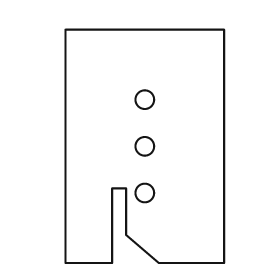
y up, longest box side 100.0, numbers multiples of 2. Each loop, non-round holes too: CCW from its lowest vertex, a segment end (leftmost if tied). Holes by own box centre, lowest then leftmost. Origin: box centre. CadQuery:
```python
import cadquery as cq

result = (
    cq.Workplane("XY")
    .moveTo(-34.0, -50.0)
    .lineTo(-14.0, -50.0)
    .lineTo(-14.0, -18.0)
    .lineTo(-8.0, -18.0)
    .lineTo(-8.0, -38.0)
    .lineTo(6.0, -50.0)
    .lineTo(34.0, -50.0)
    .lineTo(34.0, 50.0)
    .lineTo(-34.0, 50.0)
    .close()
    .moveTo(0.0, -20.0)
    .circle(4.0)
    .moveTo(0.0, 0.0)
    .circle(4.0)
    .moveTo(0.0, 20.0)
    .circle(4.0)
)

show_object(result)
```